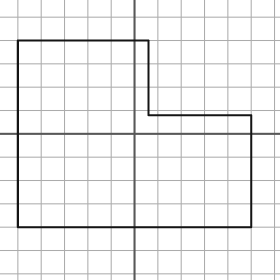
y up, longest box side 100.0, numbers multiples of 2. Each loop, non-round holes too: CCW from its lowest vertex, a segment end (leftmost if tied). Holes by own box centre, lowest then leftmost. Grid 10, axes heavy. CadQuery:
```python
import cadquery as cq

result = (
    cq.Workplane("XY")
    .moveTo(-50.0, -40.0)
    .lineTo(50.0, -40.0)
    .lineTo(50.0, 8.0)
    .lineTo(6.0, 8.0)
    .lineTo(6.0, 40.0)
    .lineTo(-50.0, 40.0)
    .close()
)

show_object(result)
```